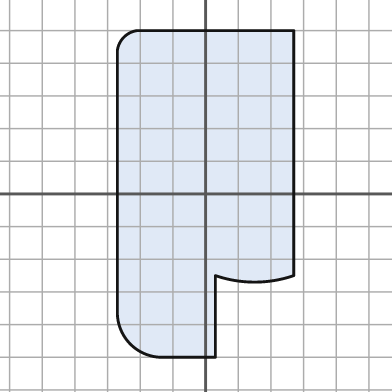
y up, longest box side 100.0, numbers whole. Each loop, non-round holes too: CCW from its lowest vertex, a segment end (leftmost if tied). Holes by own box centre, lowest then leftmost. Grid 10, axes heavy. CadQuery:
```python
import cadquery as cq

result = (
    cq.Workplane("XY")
    .moveTo(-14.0, -50.0)
    .lineTo(3.0, -50.0)
    .lineTo(3.0, -25.0)
    .threePointArc((15.0, -27.0), (27.0, -25.0))
    .lineTo(27.0, 50.0)
    .lineTo(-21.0, 50.0)
    .threePointArc((-25.0, 48.0), (-27.0, 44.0))
    .lineTo(-27.0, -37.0)
    .threePointArc((-23.0, -46.0), (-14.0, -50.0))
    .close()
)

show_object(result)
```